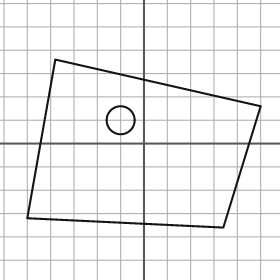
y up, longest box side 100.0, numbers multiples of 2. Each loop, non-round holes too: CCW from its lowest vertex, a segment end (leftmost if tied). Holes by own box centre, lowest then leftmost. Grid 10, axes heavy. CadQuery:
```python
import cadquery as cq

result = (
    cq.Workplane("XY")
    .moveTo(34.0, -36.0)
    .lineTo(50.0, 16.0)
    .lineTo(-38.0, 36.0)
    .lineTo(-50.0, -32.0)
    .close()
    .moveTo(-10.0, 10.0)
    .circle(6.0)
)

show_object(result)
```